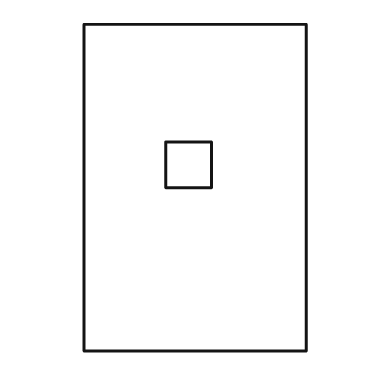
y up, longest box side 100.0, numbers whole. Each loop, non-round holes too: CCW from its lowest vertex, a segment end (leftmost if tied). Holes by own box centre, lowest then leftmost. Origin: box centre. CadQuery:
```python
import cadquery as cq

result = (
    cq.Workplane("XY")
    .moveTo(-34.0, -50.0)
    .lineTo(34.0, -50.0)
    .lineTo(34.0, 50.0)
    .lineTo(-34.0, 50.0)
    .close()
    .moveTo(-9.0, 0.0)
    .lineTo(5.0, 0.0)
    .lineTo(5.0, 14.0)
    .lineTo(-9.0, 14.0)
    .close()
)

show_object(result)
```